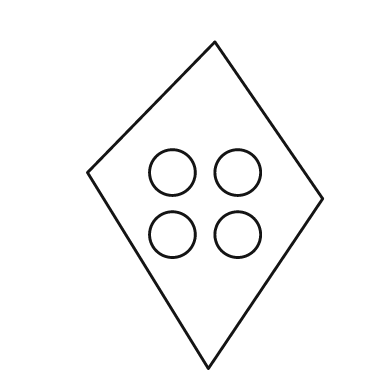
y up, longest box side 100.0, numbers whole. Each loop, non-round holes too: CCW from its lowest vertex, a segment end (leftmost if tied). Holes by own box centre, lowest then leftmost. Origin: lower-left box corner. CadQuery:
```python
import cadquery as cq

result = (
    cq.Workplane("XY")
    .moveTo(37.0, 0.0)
    .lineTo(72.0, 52.0)
    .lineTo(39.0, 100.0)
    .lineTo(0.0, 60.0)
    .close()
    .moveTo(26.0, 41.0)
    .circle(7.0)
    .moveTo(46.0, 41.0)
    .circle(7.0)
    .moveTo(26.0, 60.0)
    .circle(7.0)
    .moveTo(46.0, 60.0)
    .circle(7.0)
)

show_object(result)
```